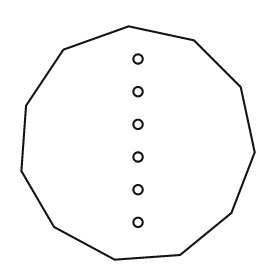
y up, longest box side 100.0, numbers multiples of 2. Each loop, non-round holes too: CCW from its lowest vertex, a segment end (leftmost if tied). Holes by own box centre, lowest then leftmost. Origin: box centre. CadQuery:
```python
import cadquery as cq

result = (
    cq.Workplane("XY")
    .moveTo(-10.0, -50.0)
    .lineTo(18.0, -48.0)
    .lineTo(40.0, -30.0)
    .lineTo(50.0, -4.0)
    .lineTo(44.0, 24.0)
    .lineTo(24.0, 44.0)
    .lineTo(-4.0, 50.0)
    .lineTo(-32.0, 40.0)
    .lineTo(-48.0, 16.0)
    .lineTo(-50.0, -12.0)
    .lineTo(-36.0, -36.0)
    .close()
    .moveTo(0.0, -34.0)
    .circle(2.0)
    .moveTo(0.0, -20.0)
    .circle(2.0)
    .moveTo(0.0, -6.0)
    .circle(2.0)
    .moveTo(0.0, 8.0)
    .circle(2.0)
    .moveTo(0.0, 22.0)
    .circle(2.0)
    .moveTo(0.0, 36.0)
    .circle(2.0)
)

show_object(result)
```